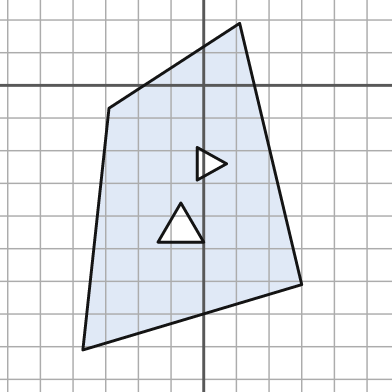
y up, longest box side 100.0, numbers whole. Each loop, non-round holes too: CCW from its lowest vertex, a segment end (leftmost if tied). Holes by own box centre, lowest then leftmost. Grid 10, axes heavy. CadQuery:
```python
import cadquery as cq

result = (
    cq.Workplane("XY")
    .moveTo(-37.0, -81.0)
    .lineTo(30.0, -61.0)
    .lineTo(11.0, 19.0)
    .lineTo(-29.0, -7.0)
    .close()
    .moveTo(-14.0, -48.0)
    .lineTo(0.0, -48.0)
    .lineTo(-7.0, -36.0)
    .close()
    .moveTo(-2.0, -29.0)
    .lineTo(7.0, -24.0)
    .lineTo(-2.0, -19.0)
    .close()
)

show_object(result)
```